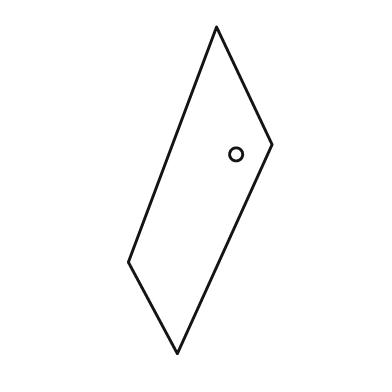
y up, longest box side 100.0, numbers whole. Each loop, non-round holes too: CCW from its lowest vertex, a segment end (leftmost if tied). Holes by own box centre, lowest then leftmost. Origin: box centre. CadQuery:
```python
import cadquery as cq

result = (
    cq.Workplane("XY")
    .moveTo(-7.0, -50.0)
    .lineTo(22.0, 14.0)
    .lineTo(5.0, 50.0)
    .lineTo(-22.0, -22.0)
    .close()
    .moveTo(11.0, 11.0)
    .circle(2.0)
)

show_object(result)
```